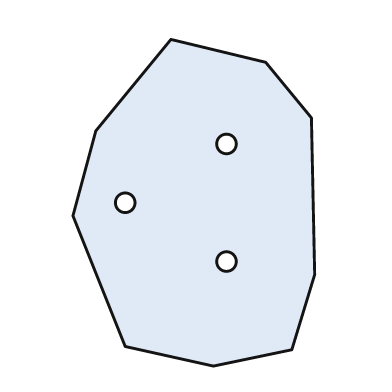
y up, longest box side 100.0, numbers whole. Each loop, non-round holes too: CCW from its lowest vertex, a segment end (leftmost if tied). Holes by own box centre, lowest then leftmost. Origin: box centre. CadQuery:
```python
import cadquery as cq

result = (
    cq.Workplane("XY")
    .moveTo(6.0, -50.0)
    .lineTo(30.0, -45.0)
    .lineTo(37.0, -22.0)
    .lineTo(36.0, 26.0)
    .lineTo(22.0, 43.0)
    .lineTo(-7.0, 50.0)
    .lineTo(-30.0, 22.0)
    .lineTo(-37.0, -4.0)
    .lineTo(-21.0, -44.0)
    .close()
    .moveTo(10.0, -18.0)
    .circle(3.0)
    .moveTo(-21.0, 0.0)
    .circle(3.0)
    .moveTo(10.0, 18.0)
    .circle(3.0)
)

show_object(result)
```